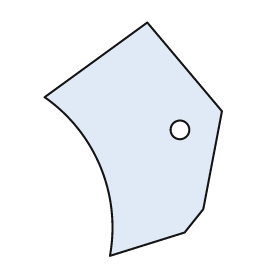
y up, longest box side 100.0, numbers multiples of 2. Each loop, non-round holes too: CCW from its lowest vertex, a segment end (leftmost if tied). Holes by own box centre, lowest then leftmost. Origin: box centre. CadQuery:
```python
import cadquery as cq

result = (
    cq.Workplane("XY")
    .moveTo(-10.0, -50.0)
    .lineTo(22.0, -40.0)
    .lineTo(30.0, -30.0)
    .lineTo(38.0, 12.0)
    .lineTo(6.0, 50.0)
    .lineTo(-38.0, 18.0)
    .threePointArc((-14.0, -12.0), (-10.0, -50.0))
    .close()
    .moveTo(20.0, 4.0)
    .circle(4.0)
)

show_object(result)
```